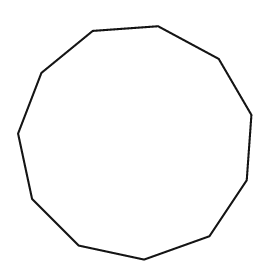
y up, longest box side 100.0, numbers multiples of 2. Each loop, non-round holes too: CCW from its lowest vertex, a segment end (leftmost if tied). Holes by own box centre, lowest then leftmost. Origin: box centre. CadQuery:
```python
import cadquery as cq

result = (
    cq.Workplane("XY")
    .moveTo(4.0, -50.0)
    .lineTo(32.0, -40.0)
    .lineTo(48.0, -16.0)
    .lineTo(50.0, 12.0)
    .lineTo(36.0, 36.0)
    .lineTo(10.0, 50.0)
    .lineTo(-18.0, 48.0)
    .lineTo(-40.0, 30.0)
    .lineTo(-50.0, 4.0)
    .lineTo(-44.0, -24.0)
    .lineTo(-24.0, -44.0)
    .close()
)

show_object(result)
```